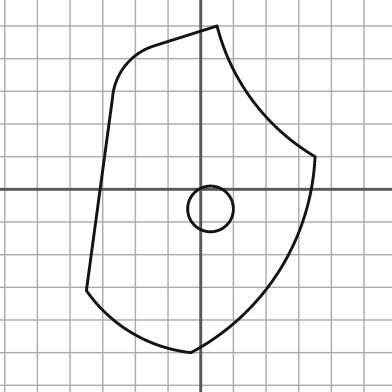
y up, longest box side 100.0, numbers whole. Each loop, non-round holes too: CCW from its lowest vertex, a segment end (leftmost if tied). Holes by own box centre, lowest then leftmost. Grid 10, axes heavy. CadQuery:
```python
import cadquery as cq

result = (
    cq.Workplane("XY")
    .moveTo(-3.0, -50.0)
    .threePointArc((24.0, -25.0), (35.0, 10.0))
    .threePointArc((16.0, 27.0), (5.0, 50.0))
    .lineTo(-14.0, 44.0)
    .threePointArc((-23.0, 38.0), (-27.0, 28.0))
    .lineTo(-35.0, -31.0)
    .threePointArc((-21.0, -44.0), (-3.0, -50.0))
    .close()
    .moveTo(3.0, -6.0)
    .circle(7.0)
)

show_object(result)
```